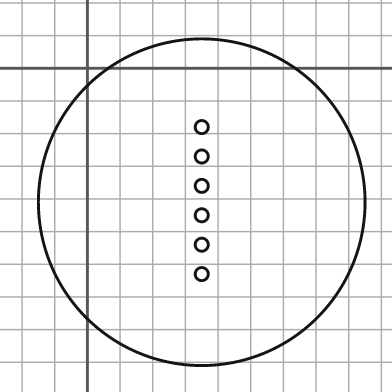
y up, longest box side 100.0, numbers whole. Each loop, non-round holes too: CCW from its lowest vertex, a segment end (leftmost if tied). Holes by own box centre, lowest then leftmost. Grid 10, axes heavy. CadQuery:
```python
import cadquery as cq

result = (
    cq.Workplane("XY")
    .moveTo(35.0, -41.0)
    .circle(50.0)
    .moveTo(35.0, -63.0)
    .circle(2.0)
    .moveTo(35.0, -54.0)
    .circle(2.0)
    .moveTo(35.0, -45.0)
    .circle(2.0)
    .moveTo(35.0, -36.0)
    .circle(2.0)
    .moveTo(35.0, -27.0)
    .circle(2.0)
    .moveTo(35.0, -18.0)
    .circle(2.0)
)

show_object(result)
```